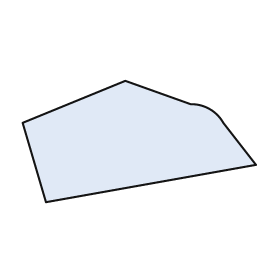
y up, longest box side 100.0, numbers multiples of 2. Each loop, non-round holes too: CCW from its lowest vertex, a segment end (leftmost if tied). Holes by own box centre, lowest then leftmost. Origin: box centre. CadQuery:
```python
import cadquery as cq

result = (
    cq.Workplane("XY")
    .moveTo(-40.0, -26.0)
    .lineTo(50.0, -10.0)
    .lineTo(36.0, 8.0)
    .threePointArc((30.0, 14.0), (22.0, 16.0))
    .lineTo(-6.0, 26.0)
    .lineTo(-50.0, 8.0)
    .close()
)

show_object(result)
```